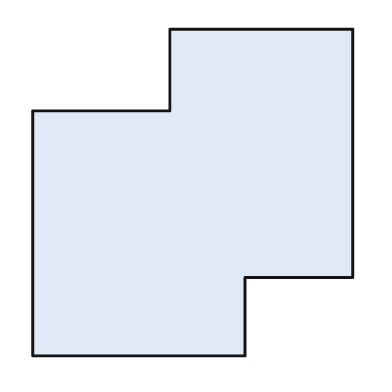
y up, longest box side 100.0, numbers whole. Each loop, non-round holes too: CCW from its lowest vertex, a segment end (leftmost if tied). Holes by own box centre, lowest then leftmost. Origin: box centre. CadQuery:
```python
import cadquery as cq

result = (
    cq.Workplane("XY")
    .moveTo(-49.0, -50.0)
    .lineTo(16.0, -50.0)
    .lineTo(16.0, -26.0)
    .lineTo(49.0, -26.0)
    .lineTo(49.0, 50.0)
    .lineTo(-7.0, 50.0)
    .lineTo(-7.0, 25.0)
    .lineTo(-49.0, 25.0)
    .close()
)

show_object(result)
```